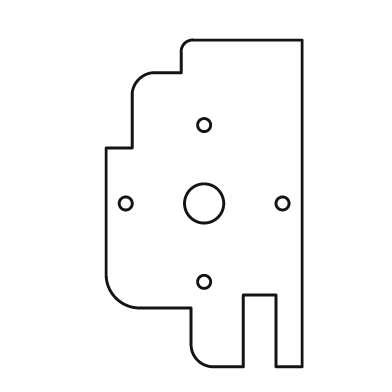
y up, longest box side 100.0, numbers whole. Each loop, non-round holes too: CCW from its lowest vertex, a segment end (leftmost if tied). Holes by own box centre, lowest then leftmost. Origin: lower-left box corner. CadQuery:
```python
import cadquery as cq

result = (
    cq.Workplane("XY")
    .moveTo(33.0, 0.0)
    .lineTo(42.0, 0.0)
    .lineTo(42.0, 22.0)
    .lineTo(52.0, 22.0)
    .lineTo(52.0, 0.0)
    .lineTo(60.0, 0.0)
    .lineTo(60.0, 100.0)
    .lineTo(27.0, 100.0)
    .threePointArc((24.0, 99.0), (23.0, 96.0))
    .lineTo(23.0, 90.0)
    .lineTo(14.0, 90.0)
    .threePointArc((10.0, 88.0), (8.0, 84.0))
    .lineTo(8.0, 67.0)
    .lineTo(0.0, 67.0)
    .lineTo(0.0, 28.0)
    .threePointArc((3.0, 21.0), (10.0, 18.0))
    .lineTo(26.0, 18.0)
    .lineTo(26.0, 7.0)
    .threePointArc((28.0, 2.0), (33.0, 0.0))
    .close()
    .moveTo(30.0, 26.0)
    .circle(2.0)
    .moveTo(6.0, 50.0)
    .circle(2.0)
    .moveTo(30.0, 50.0)
    .circle(6.0)
    .moveTo(54.0, 50.0)
    .circle(2.0)
    .moveTo(30.0, 74.0)
    .circle(2.0)
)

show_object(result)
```